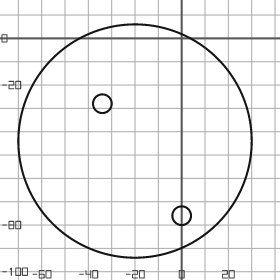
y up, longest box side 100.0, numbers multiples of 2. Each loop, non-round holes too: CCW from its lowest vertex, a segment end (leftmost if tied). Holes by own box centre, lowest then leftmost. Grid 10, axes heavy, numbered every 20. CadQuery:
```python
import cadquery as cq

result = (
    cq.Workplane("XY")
    .moveTo(-20.0, -44.0)
    .circle(50.0)
    .moveTo(0.0, -76.0)
    .circle(4.0)
    .moveTo(-34.0, -28.0)
    .circle(4.0)
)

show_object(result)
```